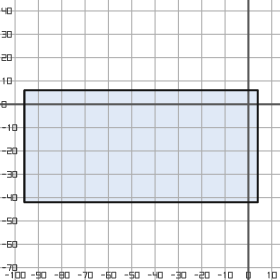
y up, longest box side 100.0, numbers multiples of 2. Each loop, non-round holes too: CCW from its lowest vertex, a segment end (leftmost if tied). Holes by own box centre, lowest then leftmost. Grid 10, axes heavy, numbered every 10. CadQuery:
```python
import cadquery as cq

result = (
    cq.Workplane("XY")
    .moveTo(-96.0, -42.0)
    .lineTo(4.0, -42.0)
    .lineTo(4.0, 6.0)
    .lineTo(-96.0, 6.0)
    .close()
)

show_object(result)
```